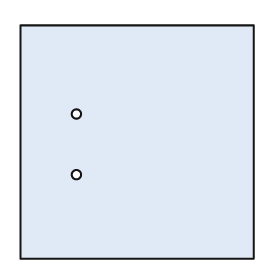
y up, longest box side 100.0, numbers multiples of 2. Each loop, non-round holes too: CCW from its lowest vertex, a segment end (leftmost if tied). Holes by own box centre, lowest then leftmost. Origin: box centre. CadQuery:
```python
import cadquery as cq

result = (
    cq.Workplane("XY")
    .moveTo(-50.0, -50.0)
    .lineTo(50.0, -50.0)
    .lineTo(50.0, 50.0)
    .lineTo(-50.0, 50.0)
    .close()
    .moveTo(-26.0, -14.0)
    .circle(2.0)
    .moveTo(-26.0, 12.0)
    .circle(2.0)
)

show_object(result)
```